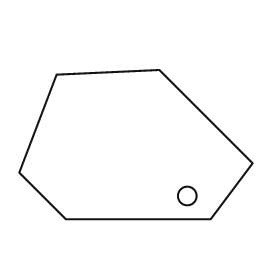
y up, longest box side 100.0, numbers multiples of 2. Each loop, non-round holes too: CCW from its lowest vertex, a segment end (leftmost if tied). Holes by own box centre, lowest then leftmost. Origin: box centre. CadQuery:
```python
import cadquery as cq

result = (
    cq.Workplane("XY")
    .moveTo(-30.0, -32.0)
    .lineTo(32.0, -32.0)
    .lineTo(50.0, -8.0)
    .lineTo(10.0, 32.0)
    .lineTo(-34.0, 30.0)
    .lineTo(-50.0, -12.0)
    .close()
    .moveTo(22.0, -22.0)
    .circle(4.0)
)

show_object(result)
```